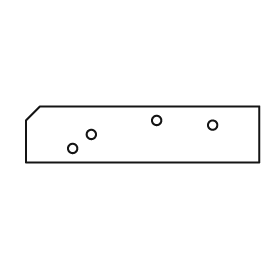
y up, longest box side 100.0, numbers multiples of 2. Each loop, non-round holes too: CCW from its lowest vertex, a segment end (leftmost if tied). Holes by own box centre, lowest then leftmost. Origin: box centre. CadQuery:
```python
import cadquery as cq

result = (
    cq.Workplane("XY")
    .moveTo(-50.0, -12.0)
    .lineTo(50.0, -12.0)
    .lineTo(50.0, 12.0)
    .lineTo(-44.0, 12.0)
    .lineTo(-50.0, 6.0)
    .close()
    .moveTo(-30.0, -6.0)
    .circle(2.0)
    .moveTo(-22.0, 0.0)
    .circle(2.0)
    .moveTo(30.0, 4.0)
    .circle(2.0)
    .moveTo(6.0, 6.0)
    .circle(2.0)
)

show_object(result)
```